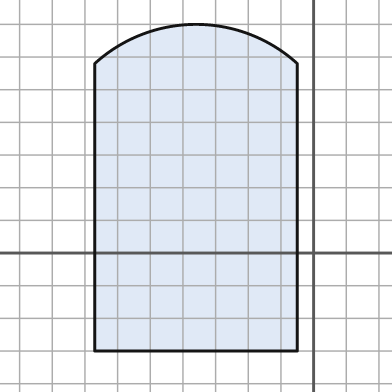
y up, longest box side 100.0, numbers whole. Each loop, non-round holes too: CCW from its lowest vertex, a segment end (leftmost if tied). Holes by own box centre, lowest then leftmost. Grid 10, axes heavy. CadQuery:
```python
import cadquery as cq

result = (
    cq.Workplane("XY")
    .moveTo(-67.0, -30.0)
    .lineTo(-5.0, -30.0)
    .lineTo(-5.0, 58.0)
    .threePointArc((-36.0, 70.0), (-67.0, 58.0))
    .close()
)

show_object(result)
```